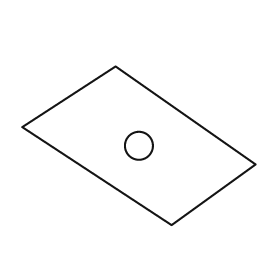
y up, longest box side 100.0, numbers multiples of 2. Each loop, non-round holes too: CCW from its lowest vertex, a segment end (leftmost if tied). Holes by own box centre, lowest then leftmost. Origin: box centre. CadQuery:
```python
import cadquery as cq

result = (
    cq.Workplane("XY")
    .moveTo(14.0, -34.0)
    .lineTo(50.0, -8.0)
    .lineTo(-10.0, 34.0)
    .lineTo(-50.0, 8.0)
    .close()
    .moveTo(0.0, 0.0)
    .circle(6.0)
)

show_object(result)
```